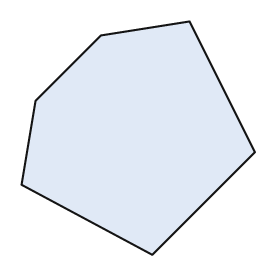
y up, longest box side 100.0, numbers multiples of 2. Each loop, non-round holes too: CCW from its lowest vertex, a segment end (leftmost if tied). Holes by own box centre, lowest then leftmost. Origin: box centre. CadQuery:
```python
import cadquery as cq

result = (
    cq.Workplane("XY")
    .moveTo(6.0, -50.0)
    .lineTo(50.0, -6.0)
    .lineTo(22.0, 50.0)
    .lineTo(-16.0, 44.0)
    .lineTo(-44.0, 16.0)
    .lineTo(-50.0, -20.0)
    .close()
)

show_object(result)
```